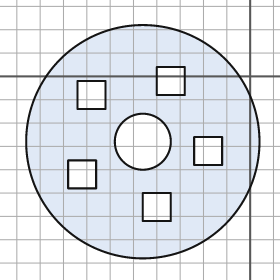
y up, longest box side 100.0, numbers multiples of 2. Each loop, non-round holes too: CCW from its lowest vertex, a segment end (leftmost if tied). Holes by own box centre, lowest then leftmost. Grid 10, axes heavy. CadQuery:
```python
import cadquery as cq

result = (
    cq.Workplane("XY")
    .moveTo(-46.0, -28.0)
    .circle(50.0)
    .moveTo(-46.0, -62.0)
    .lineTo(-34.0, -62.0)
    .lineTo(-34.0, -50.0)
    .lineTo(-46.0, -50.0)
    .close()
    .moveTo(-78.0, -48.0)
    .lineTo(-66.0, -48.0)
    .lineTo(-66.0, -36.0)
    .lineTo(-78.0, -36.0)
    .close()
    .moveTo(-24.0, -38.0)
    .lineTo(-12.0, -38.0)
    .lineTo(-12.0, -26.0)
    .lineTo(-24.0, -26.0)
    .close()
    .moveTo(-46.0, -28.0)
    .circle(12.0)
    .moveTo(-74.0, -14.0)
    .lineTo(-62.0, -14.0)
    .lineTo(-62.0, -2.0)
    .lineTo(-74.0, -2.0)
    .close()
    .moveTo(-40.0, -8.0)
    .lineTo(-28.0, -8.0)
    .lineTo(-28.0, 4.0)
    .lineTo(-40.0, 4.0)
    .close()
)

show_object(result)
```